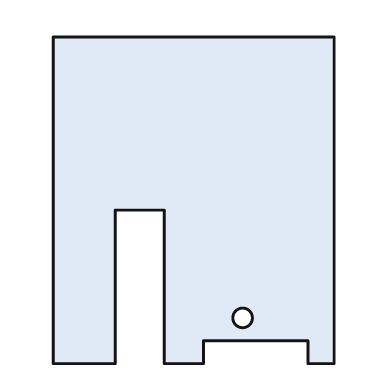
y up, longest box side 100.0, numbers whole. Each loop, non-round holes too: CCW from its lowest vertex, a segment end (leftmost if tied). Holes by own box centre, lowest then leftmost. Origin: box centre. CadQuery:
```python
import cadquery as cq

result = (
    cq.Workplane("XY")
    .moveTo(-43.0, -50.0)
    .lineTo(-24.0, -50.0)
    .lineTo(-24.0, -3.0)
    .lineTo(-9.0, -3.0)
    .lineTo(-9.0, -50.0)
    .lineTo(3.0, -50.0)
    .lineTo(3.0, -43.0)
    .lineTo(35.0, -43.0)
    .lineTo(35.0, -50.0)
    .lineTo(43.0, -50.0)
    .lineTo(43.0, 50.0)
    .lineTo(-43.0, 50.0)
    .close()
    .moveTo(15.0, -36.0)
    .circle(3.0)
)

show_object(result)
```